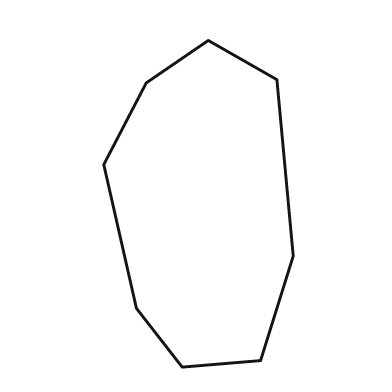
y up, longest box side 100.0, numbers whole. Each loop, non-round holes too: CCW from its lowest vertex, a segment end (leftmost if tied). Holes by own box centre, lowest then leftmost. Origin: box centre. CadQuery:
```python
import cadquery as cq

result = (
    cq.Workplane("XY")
    .moveTo(-5.0, -50.0)
    .lineTo(19.0, -48.0)
    .lineTo(29.0, -16.0)
    .lineTo(24.0, 38.0)
    .lineTo(3.0, 50.0)
    .lineTo(-16.0, 37.0)
    .lineTo(-29.0, 12.0)
    .lineTo(-19.0, -32.0)
    .close()
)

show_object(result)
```